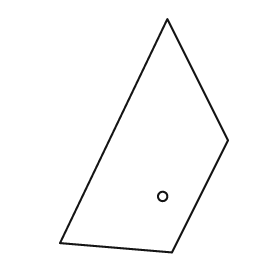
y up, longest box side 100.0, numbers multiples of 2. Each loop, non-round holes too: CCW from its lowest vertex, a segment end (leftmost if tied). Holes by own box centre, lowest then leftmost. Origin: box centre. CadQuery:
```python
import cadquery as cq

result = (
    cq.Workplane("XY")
    .moveTo(12.0, -50.0)
    .lineTo(36.0, -2.0)
    .lineTo(10.0, 50.0)
    .lineTo(-36.0, -46.0)
    .close()
    .moveTo(8.0, -26.0)
    .circle(2.0)
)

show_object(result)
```